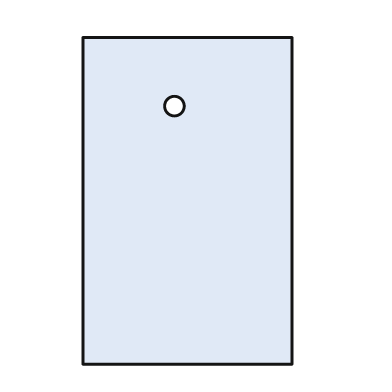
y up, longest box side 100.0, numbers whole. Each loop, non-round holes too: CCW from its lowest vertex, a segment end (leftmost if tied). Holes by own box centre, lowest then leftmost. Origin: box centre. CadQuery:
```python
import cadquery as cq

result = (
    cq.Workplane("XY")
    .moveTo(-32.0, -50.0)
    .lineTo(32.0, -50.0)
    .lineTo(32.0, 50.0)
    .lineTo(-32.0, 50.0)
    .close()
    .moveTo(-4.0, 29.0)
    .circle(3.0)
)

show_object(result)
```